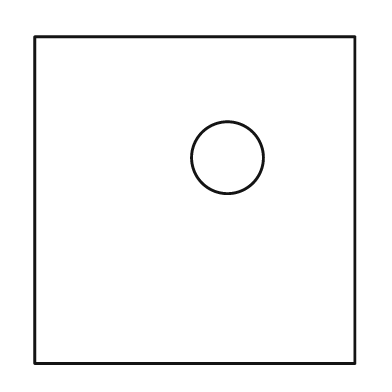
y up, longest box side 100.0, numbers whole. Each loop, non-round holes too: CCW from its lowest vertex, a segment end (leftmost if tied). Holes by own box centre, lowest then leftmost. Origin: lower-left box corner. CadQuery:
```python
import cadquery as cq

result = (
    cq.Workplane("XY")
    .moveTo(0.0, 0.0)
    .lineTo(98.0, 0.0)
    .lineTo(98.0, 100.0)
    .lineTo(0.0, 100.0)
    .close()
    .moveTo(59.0, 63.0)
    .circle(11.0)
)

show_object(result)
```